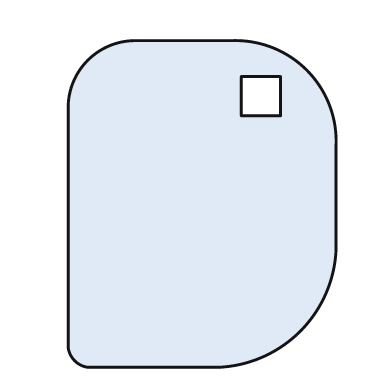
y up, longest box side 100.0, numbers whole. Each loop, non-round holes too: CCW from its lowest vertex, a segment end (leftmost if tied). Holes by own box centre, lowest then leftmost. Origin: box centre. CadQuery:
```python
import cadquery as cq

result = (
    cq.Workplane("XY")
    .moveTo(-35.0, -50.0)
    .lineTo(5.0, -50.0)
    .threePointArc((30.0, -39.0), (41.0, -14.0))
    .lineTo(41.0, 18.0)
    .threePointArc((32.0, 41.0), (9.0, 50.0))
    .lineTo(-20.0, 50.0)
    .threePointArc((-35.0, 44.0), (-41.0, 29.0))
    .lineTo(-41.0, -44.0)
    .threePointArc((-39.0, -48.0), (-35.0, -50.0))
    .close()
    .moveTo(12.0, 27.0)
    .lineTo(24.0, 27.0)
    .lineTo(24.0, 39.0)
    .lineTo(12.0, 39.0)
    .close()
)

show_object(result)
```